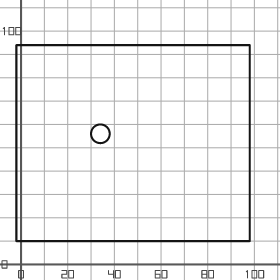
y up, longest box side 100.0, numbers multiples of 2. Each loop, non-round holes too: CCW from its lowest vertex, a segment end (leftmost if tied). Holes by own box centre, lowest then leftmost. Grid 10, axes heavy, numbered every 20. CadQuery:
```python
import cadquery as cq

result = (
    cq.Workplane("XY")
    .moveTo(-2.0, 10.0)
    .lineTo(98.0, 10.0)
    .lineTo(98.0, 94.0)
    .lineTo(-2.0, 94.0)
    .close()
    .moveTo(34.0, 56.0)
    .circle(4.0)
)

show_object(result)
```